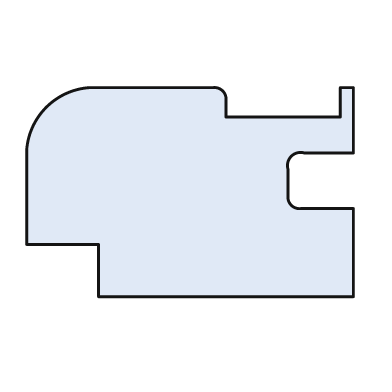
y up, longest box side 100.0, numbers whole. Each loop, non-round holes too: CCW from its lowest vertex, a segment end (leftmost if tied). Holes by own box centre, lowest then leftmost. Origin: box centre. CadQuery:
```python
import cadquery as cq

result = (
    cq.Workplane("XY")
    .moveTo(-28.0, -32.0)
    .lineTo(50.0, -32.0)
    .lineTo(50.0, -5.0)
    .lineTo(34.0, -5.0)
    .threePointArc((31.0, -4.0), (30.0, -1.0))
    .lineTo(30.0, 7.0)
    .threePointArc((31.0, 11.0), (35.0, 12.0))
    .lineTo(50.0, 12.0)
    .lineTo(50.0, 32.0)
    .lineTo(46.0, 32.0)
    .lineTo(46.0, 23.0)
    .lineTo(11.0, 23.0)
    .lineTo(11.0, 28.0)
    .threePointArc((10.0, 31.0), (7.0, 32.0))
    .lineTo(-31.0, 32.0)
    .threePointArc((-44.0, 26.0), (-50.0, 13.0))
    .lineTo(-50.0, -16.0)
    .lineTo(-28.0, -16.0)
    .close()
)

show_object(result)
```